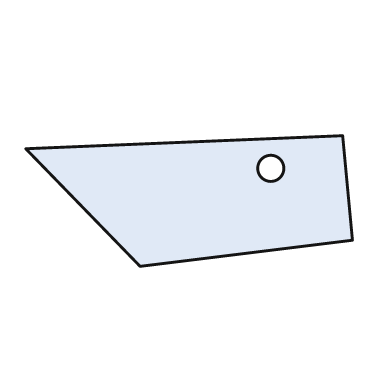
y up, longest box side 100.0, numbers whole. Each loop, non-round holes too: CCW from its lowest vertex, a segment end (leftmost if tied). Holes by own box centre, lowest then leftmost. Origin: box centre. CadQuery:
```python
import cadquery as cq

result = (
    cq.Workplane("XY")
    .moveTo(-15.0, -20.0)
    .lineTo(50.0, -12.0)
    .lineTo(47.0, 20.0)
    .lineTo(-50.0, 16.0)
    .close()
    .moveTo(25.0, 10.0)
    .circle(4.0)
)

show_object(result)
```